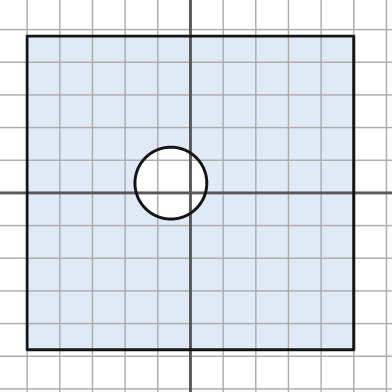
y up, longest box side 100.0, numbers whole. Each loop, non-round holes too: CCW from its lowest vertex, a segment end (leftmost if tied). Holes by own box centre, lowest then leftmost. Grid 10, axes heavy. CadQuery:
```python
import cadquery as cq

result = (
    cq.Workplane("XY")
    .moveTo(-50.0, -48.0)
    .lineTo(50.0, -48.0)
    .lineTo(50.0, 48.0)
    .lineTo(-50.0, 48.0)
    .close()
    .moveTo(-6.0, 3.0)
    .circle(11.0)
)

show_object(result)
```